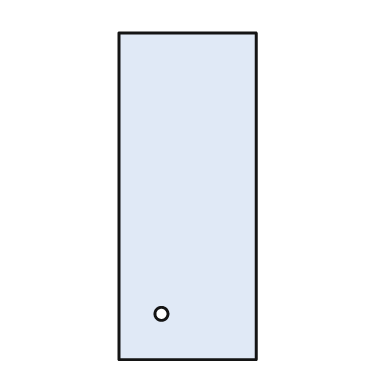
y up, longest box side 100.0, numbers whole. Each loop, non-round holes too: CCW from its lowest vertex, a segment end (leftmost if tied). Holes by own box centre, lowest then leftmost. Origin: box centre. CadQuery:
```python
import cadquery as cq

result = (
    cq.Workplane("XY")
    .moveTo(-21.0, -50.0)
    .lineTo(21.0, -50.0)
    .lineTo(21.0, 50.0)
    .lineTo(-21.0, 50.0)
    .close()
    .moveTo(-8.0, -36.0)
    .circle(2.0)
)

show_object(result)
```